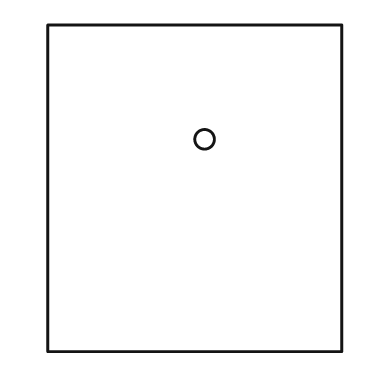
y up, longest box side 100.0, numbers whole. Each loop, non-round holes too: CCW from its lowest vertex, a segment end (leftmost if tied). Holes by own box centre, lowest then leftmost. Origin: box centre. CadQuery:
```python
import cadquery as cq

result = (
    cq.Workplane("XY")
    .moveTo(-45.0, -50.0)
    .lineTo(45.0, -50.0)
    .lineTo(45.0, 50.0)
    .lineTo(-45.0, 50.0)
    .close()
    .moveTo(3.0, 15.0)
    .circle(3.0)
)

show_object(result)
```